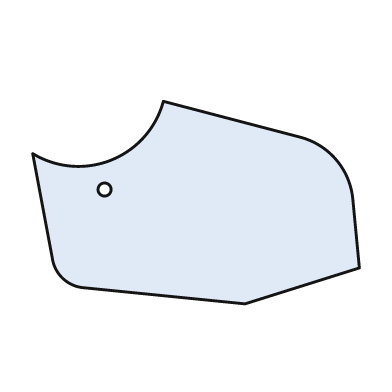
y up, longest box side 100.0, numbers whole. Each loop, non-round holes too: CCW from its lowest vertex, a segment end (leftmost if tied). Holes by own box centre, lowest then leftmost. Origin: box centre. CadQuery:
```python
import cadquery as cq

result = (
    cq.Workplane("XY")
    .moveTo(15.0, -31.0)
    .lineTo(50.0, -20.0)
    .lineTo(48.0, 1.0)
    .threePointArc((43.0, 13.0), (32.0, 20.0))
    .lineTo(-10.0, 31.0)
    .threePointArc((-26.0, 13.0), (-50.0, 15.0))
    .lineTo(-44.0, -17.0)
    .threePointArc((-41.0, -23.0), (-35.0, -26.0))
    .close()
    .moveTo(-28.0, 4.0)
    .circle(2.0)
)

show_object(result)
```